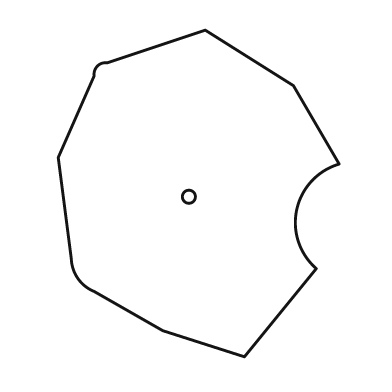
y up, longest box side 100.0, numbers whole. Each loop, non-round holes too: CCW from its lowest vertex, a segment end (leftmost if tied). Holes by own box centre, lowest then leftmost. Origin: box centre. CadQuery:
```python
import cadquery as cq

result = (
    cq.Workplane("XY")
    .moveTo(14.0, -50.0)
    .lineTo(36.0, -23.0)
    .threePointArc((30.0, -5.0), (43.0, 9.0))
    .lineTo(29.0, 33.0)
    .lineTo(2.0, 50.0)
    .lineTo(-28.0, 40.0)
    .threePointArc((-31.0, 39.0), (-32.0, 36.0))
    .lineTo(-43.0, 11.0)
    .lineTo(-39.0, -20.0)
    .threePointArc((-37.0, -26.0), (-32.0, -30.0))
    .lineTo(-11.0, -42.0)
    .close()
    .moveTo(-3.0, -1.0)
    .circle(2.0)
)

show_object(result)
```